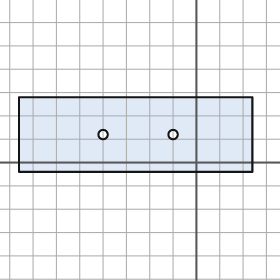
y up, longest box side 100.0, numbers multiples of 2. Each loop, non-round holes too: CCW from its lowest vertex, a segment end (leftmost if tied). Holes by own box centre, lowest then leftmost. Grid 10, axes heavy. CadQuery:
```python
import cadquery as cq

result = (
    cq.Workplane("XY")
    .moveTo(-76.0, -4.0)
    .lineTo(24.0, -4.0)
    .lineTo(24.0, 28.0)
    .lineTo(-76.0, 28.0)
    .close()
    .moveTo(-40.0, 12.0)
    .circle(2.0)
    .moveTo(-10.0, 12.0)
    .circle(2.0)
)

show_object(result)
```